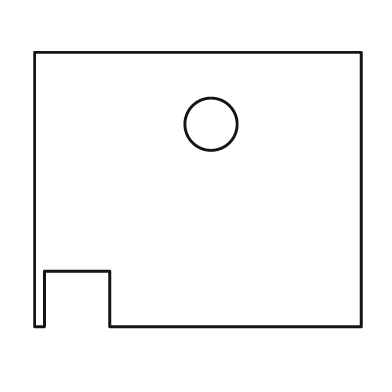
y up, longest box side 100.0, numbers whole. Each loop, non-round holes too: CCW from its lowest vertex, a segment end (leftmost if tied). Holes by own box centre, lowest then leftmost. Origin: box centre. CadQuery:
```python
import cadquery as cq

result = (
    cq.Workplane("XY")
    .moveTo(-50.0, -42.0)
    .lineTo(-47.0, -42.0)
    .lineTo(-47.0, -25.0)
    .lineTo(-27.0, -25.0)
    .lineTo(-27.0, -42.0)
    .lineTo(50.0, -42.0)
    .lineTo(50.0, 42.0)
    .lineTo(-50.0, 42.0)
    .close()
    .moveTo(4.0, 20.0)
    .circle(8.0)
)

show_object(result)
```